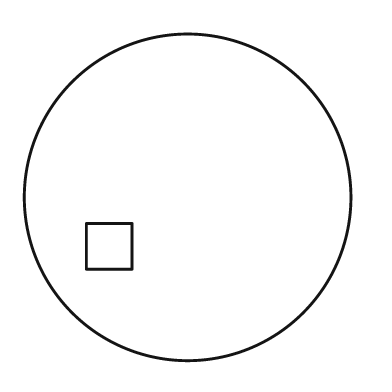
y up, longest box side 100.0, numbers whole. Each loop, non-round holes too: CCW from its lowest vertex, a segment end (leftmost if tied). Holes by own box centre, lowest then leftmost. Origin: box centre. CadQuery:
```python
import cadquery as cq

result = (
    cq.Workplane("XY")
    .moveTo(0.0, 0.0)
    .circle(50.0)
    .moveTo(-31.0, -22.0)
    .lineTo(-17.0, -22.0)
    .lineTo(-17.0, -8.0)
    .lineTo(-31.0, -8.0)
    .close()
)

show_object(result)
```